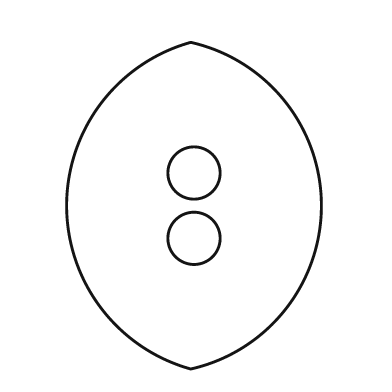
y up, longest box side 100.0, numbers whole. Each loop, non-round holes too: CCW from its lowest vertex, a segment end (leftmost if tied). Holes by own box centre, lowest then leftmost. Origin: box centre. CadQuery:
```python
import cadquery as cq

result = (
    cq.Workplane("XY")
    .moveTo(-1.0, -50.0)
    .threePointArc((39.0, 0.0), (-1.0, 50.0))
    .threePointArc((-39.0, 0.0), (-1.0, -50.0))
    .close()
    .moveTo(0.0, -10.0)
    .circle(8.0)
    .moveTo(0.0, 10.0)
    .circle(8.0)
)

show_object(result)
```